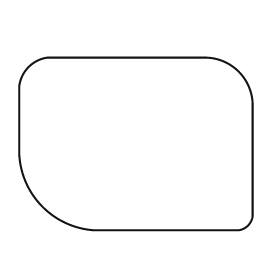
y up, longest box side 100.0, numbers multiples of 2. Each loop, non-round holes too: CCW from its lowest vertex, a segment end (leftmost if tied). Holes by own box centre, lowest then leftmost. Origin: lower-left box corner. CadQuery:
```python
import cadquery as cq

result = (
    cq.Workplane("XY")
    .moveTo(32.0, 0.0)
    .lineTo(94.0, 0.0)
    .threePointArc((98.0, 2.0), (100.0, 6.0))
    .lineTo(100.0, 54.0)
    .threePointArc((94.0, 68.0), (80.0, 74.0))
    .lineTo(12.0, 74.0)
    .threePointArc((4.0, 70.0), (0.0, 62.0))
    .lineTo(0.0, 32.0)
    .threePointArc((10.0, 10.0), (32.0, 0.0))
    .close()
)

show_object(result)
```